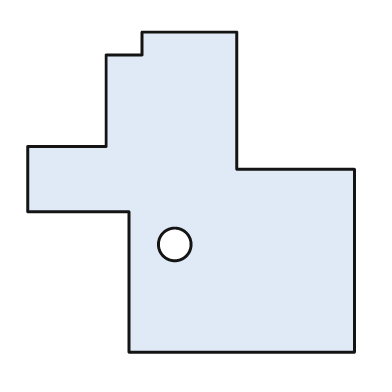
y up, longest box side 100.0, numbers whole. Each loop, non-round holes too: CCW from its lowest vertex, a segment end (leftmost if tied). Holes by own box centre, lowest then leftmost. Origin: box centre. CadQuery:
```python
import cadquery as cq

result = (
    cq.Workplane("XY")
    .moveTo(-19.0, -49.0)
    .lineTo(50.0, -49.0)
    .lineTo(50.0, 7.0)
    .lineTo(14.0, 7.0)
    .lineTo(14.0, 49.0)
    .lineTo(-15.0, 49.0)
    .lineTo(-15.0, 42.0)
    .lineTo(-26.0, 42.0)
    .lineTo(-26.0, 14.0)
    .lineTo(-50.0, 14.0)
    .lineTo(-50.0, -6.0)
    .lineTo(-19.0, -6.0)
    .close()
    .moveTo(-5.0, -16.0)
    .circle(5.0)
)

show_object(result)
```